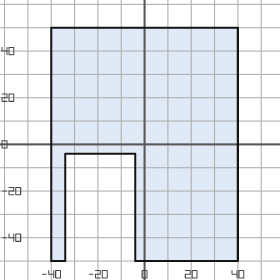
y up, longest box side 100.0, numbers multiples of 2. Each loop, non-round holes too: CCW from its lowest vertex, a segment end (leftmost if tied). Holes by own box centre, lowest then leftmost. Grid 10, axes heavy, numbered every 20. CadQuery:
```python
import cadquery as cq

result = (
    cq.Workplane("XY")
    .moveTo(-40.0, -50.0)
    .lineTo(-34.0, -50.0)
    .lineTo(-34.0, -4.0)
    .lineTo(-4.0, -4.0)
    .lineTo(-4.0, -50.0)
    .lineTo(40.0, -50.0)
    .lineTo(40.0, 50.0)
    .lineTo(-40.0, 50.0)
    .close()
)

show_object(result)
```